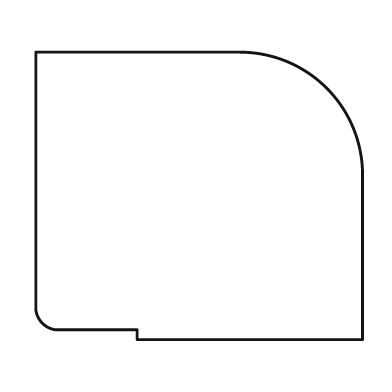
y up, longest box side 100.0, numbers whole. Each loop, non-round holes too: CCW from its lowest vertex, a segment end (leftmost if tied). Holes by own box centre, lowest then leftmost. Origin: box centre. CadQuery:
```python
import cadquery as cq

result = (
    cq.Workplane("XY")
    .moveTo(-19.0, -44.0)
    .lineTo(50.0, -44.0)
    .lineTo(50.0, 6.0)
    .threePointArc((39.0, 33.0), (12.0, 44.0))
    .lineTo(-50.0, 44.0)
    .lineTo(-50.0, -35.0)
    .threePointArc((-48.0, -39.0), (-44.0, -41.0))
    .lineTo(-19.0, -41.0)
    .close()
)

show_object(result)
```